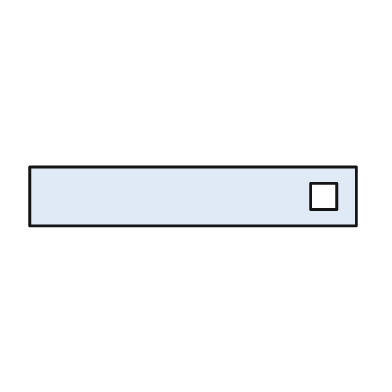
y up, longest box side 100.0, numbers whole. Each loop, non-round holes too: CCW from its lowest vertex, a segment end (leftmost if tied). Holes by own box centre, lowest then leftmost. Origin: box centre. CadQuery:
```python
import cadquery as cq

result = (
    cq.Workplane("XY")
    .moveTo(-50.0, -9.0)
    .lineTo(50.0, -9.0)
    .lineTo(50.0, 9.0)
    .lineTo(-50.0, 9.0)
    .close()
    .moveTo(36.0, -4.0)
    .lineTo(44.0, -4.0)
    .lineTo(44.0, 4.0)
    .lineTo(36.0, 4.0)
    .close()
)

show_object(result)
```